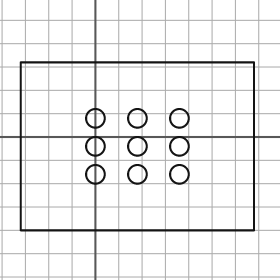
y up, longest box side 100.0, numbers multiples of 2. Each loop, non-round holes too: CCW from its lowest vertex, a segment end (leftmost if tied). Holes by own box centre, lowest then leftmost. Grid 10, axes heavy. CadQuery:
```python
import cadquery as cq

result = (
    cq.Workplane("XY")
    .moveTo(-32.0, -40.0)
    .lineTo(68.0, -40.0)
    .lineTo(68.0, 32.0)
    .lineTo(-32.0, 32.0)
    .close()
    .moveTo(0.0, -16.0)
    .circle(4.0)
    .moveTo(18.0, -16.0)
    .circle(4.0)
    .moveTo(36.0, -16.0)
    .circle(4.0)
    .moveTo(0.0, -4.0)
    .circle(4.0)
    .moveTo(18.0, -4.0)
    .circle(4.0)
    .moveTo(36.0, -4.0)
    .circle(4.0)
    .moveTo(0.0, 8.0)
    .circle(4.0)
    .moveTo(18.0, 8.0)
    .circle(4.0)
    .moveTo(36.0, 8.0)
    .circle(4.0)
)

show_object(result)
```